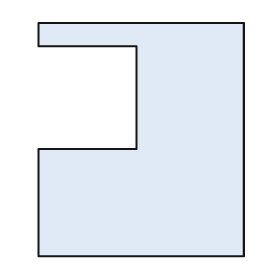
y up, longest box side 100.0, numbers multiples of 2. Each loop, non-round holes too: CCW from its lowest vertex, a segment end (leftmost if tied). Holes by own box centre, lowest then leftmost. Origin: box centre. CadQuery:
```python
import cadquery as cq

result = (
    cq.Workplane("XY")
    .moveTo(-44.0, -50.0)
    .lineTo(44.0, -50.0)
    .lineTo(44.0, 50.0)
    .lineTo(-44.0, 50.0)
    .lineTo(-44.0, 40.0)
    .lineTo(-2.0, 40.0)
    .lineTo(-2.0, -4.0)
    .lineTo(-44.0, -4.0)
    .close()
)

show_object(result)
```